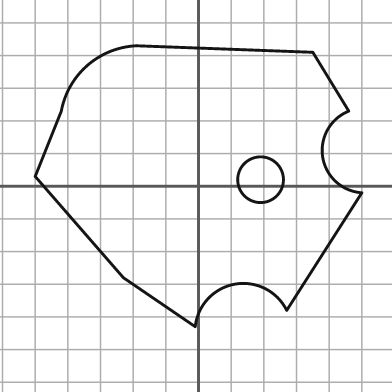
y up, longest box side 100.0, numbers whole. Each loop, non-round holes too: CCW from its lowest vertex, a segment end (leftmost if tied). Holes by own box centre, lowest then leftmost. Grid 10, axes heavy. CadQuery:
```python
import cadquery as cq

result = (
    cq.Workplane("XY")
    .moveTo(-1.0, -43.0)
    .threePointArc((11.0, -30.0), (27.0, -38.0))
    .lineTo(50.0, -2.0)
    .threePointArc((38.0, 9.0), (46.0, 23.0))
    .lineTo(35.0, 41.0)
    .lineTo(-19.0, 43.0)
    .threePointArc((-34.0, 37.0), (-42.0, 23.0))
    .lineTo(-50.0, 3.0)
    .lineTo(-23.0, -28.0)
    .close()
    .moveTo(19.0, 2.0)
    .circle(7.0)
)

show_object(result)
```